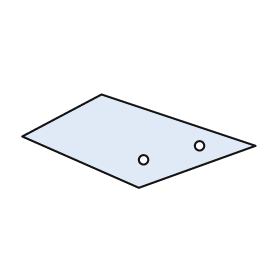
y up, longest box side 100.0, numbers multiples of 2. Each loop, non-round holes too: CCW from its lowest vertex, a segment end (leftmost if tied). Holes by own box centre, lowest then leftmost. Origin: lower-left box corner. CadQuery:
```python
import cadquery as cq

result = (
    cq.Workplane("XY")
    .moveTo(50.0, 0.0)
    .lineTo(100.0, 18.0)
    .lineTo(34.0, 40.0)
    .lineTo(0.0, 22.0)
    .close()
    .moveTo(52.0, 12.0)
    .circle(2.0)
    .moveTo(76.0, 18.0)
    .circle(2.0)
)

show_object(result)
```